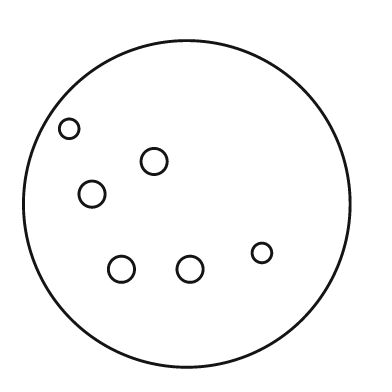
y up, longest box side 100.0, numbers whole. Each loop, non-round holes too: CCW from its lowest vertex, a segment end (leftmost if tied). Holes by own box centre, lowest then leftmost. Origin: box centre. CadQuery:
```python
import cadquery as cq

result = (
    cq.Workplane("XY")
    .moveTo(0.0, 0.0)
    .circle(50.0)
    .moveTo(-20.0, -20.0)
    .circle(4.0)
    .moveTo(1.0, -20.0)
    .circle(4.0)
    .moveTo(23.0, -15.0)
    .circle(3.0)
    .moveTo(-29.0, 3.0)
    .circle(4.0)
    .moveTo(-10.0, 13.0)
    .circle(4.0)
    .moveTo(-36.0, 23.0)
    .circle(3.0)
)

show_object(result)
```